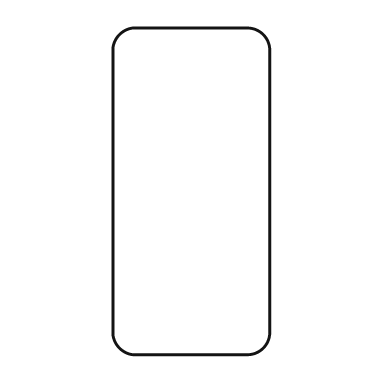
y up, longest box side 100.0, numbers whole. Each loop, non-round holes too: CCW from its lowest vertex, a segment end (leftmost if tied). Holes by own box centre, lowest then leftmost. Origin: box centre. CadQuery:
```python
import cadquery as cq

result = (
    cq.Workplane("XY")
    .moveTo(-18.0, -50.0)
    .lineTo(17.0, -50.0)
    .threePointArc((22.0, -48.0), (24.0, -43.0))
    .lineTo(24.0, 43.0)
    .threePointArc((22.0, 48.0), (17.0, 50.0))
    .lineTo(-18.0, 50.0)
    .threePointArc((-22.0, 48.0), (-24.0, 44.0))
    .lineTo(-24.0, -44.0)
    .threePointArc((-22.0, -48.0), (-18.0, -50.0))
    .close()
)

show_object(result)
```